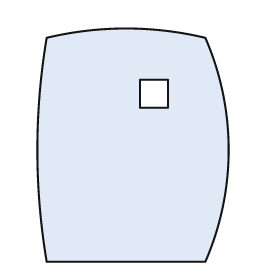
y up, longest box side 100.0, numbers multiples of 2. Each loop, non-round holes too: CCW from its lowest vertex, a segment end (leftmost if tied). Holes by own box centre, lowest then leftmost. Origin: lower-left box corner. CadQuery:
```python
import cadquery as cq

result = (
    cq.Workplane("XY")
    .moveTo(4.0, 0.0)
    .lineTo(72.0, 0.0)
    .threePointArc((82.0, 48.0), (72.0, 96.0))
    .threePointArc((38.0, 100.0), (4.0, 96.0))
    .threePointArc((0.0, 48.0), (4.0, 0.0))
    .close()
    .moveTo(44.0, 66.0)
    .lineTo(56.0, 66.0)
    .lineTo(56.0, 78.0)
    .lineTo(44.0, 78.0)
    .close()
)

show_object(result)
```